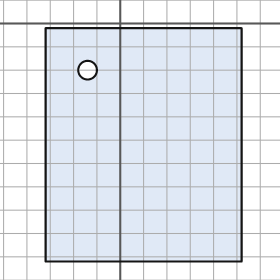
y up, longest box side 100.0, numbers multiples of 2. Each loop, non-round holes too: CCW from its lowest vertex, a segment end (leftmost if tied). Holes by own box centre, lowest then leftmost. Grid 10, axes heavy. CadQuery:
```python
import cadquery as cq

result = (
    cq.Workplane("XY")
    .moveTo(-32.0, -102.0)
    .lineTo(52.0, -102.0)
    .lineTo(52.0, -2.0)
    .lineTo(-32.0, -2.0)
    .close()
    .moveTo(-14.0, -20.0)
    .circle(4.0)
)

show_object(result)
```